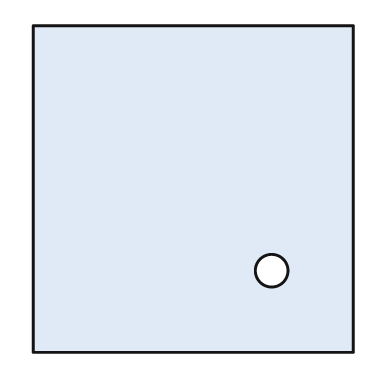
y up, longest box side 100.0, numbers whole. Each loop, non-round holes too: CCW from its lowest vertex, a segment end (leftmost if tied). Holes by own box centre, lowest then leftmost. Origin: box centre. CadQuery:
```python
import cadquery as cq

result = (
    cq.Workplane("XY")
    .moveTo(-49.0, -50.0)
    .lineTo(49.0, -50.0)
    .lineTo(49.0, 50.0)
    .lineTo(-49.0, 50.0)
    .close()
    .moveTo(24.0, -25.0)
    .circle(5.0)
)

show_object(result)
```